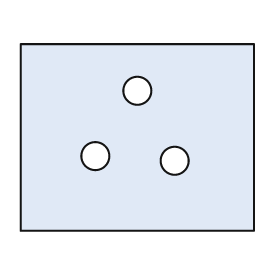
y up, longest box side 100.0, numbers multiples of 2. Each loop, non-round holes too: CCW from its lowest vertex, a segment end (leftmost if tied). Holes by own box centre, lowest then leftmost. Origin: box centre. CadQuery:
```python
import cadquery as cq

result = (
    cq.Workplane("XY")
    .moveTo(-50.0, -40.0)
    .lineTo(50.0, -40.0)
    .lineTo(50.0, 40.0)
    .lineTo(-50.0, 40.0)
    .close()
    .moveTo(16.0, -10.0)
    .circle(6.0)
    .moveTo(-18.0, -8.0)
    .circle(6.0)
    .moveTo(0.0, 20.0)
    .circle(6.0)
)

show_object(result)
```